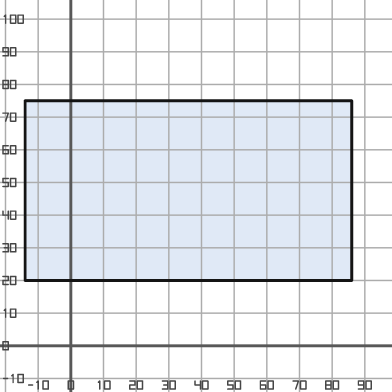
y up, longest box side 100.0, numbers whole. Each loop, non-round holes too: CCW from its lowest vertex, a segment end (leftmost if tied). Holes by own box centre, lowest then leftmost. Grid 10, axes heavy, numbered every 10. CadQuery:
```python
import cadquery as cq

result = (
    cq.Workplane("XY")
    .moveTo(-14.0, 20.0)
    .lineTo(86.0, 20.0)
    .lineTo(86.0, 75.0)
    .lineTo(-14.0, 75.0)
    .close()
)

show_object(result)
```